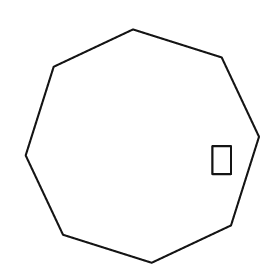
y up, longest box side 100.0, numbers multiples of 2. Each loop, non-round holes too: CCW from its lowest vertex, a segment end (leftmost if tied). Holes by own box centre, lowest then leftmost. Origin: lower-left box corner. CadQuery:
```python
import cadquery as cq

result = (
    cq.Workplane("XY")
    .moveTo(54.0, 0.0)
    .lineTo(88.0, 16.0)
    .lineTo(100.0, 54.0)
    .lineTo(84.0, 88.0)
    .lineTo(46.0, 100.0)
    .lineTo(12.0, 84.0)
    .lineTo(0.0, 46.0)
    .lineTo(16.0, 12.0)
    .close()
    .moveTo(80.0, 38.0)
    .lineTo(88.0, 38.0)
    .lineTo(88.0, 50.0)
    .lineTo(80.0, 50.0)
    .close()
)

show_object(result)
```